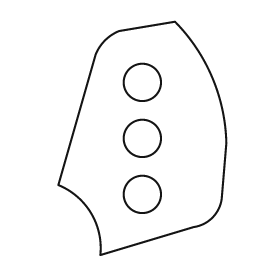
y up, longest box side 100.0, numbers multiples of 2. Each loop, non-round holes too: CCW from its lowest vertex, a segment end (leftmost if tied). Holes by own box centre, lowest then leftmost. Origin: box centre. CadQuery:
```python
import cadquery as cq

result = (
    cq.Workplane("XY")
    .moveTo(-18.0, -50.0)
    .lineTo(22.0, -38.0)
    .threePointArc((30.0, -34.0), (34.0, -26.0))
    .lineTo(36.0, -2.0)
    .threePointArc((30.0, 26.0), (14.0, 50.0))
    .lineTo(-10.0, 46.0)
    .threePointArc((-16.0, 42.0), (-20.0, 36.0))
    .lineTo(-36.0, -20.0)
    .threePointArc((-22.0, -32.0), (-18.0, -50.0))
    .close()
    .moveTo(0.0, -24.0)
    .circle(8.0)
    .moveTo(0.0, 0.0)
    .circle(8.0)
    .moveTo(0.0, 24.0)
    .circle(8.0)
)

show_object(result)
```